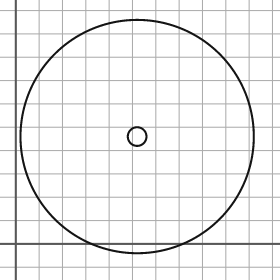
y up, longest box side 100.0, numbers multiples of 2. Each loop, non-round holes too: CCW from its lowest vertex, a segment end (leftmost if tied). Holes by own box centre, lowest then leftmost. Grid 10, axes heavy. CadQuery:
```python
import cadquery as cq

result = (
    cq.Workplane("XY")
    .moveTo(52.0, 46.0)
    .circle(50.0)
    .moveTo(52.0, 46.0)
    .circle(4.0)
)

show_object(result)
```